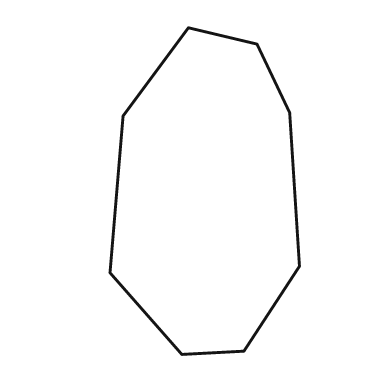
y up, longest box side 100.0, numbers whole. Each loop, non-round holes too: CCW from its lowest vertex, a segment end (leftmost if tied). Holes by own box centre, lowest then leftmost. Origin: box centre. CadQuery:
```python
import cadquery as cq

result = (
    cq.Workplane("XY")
    .moveTo(-7.0, -50.0)
    .lineTo(12.0, -49.0)
    .lineTo(29.0, -23.0)
    .lineTo(26.0, 24.0)
    .lineTo(16.0, 45.0)
    .lineTo(-5.0, 50.0)
    .lineTo(-25.0, 23.0)
    .lineTo(-29.0, -25.0)
    .close()
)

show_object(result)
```